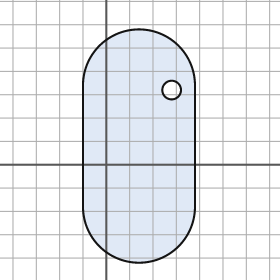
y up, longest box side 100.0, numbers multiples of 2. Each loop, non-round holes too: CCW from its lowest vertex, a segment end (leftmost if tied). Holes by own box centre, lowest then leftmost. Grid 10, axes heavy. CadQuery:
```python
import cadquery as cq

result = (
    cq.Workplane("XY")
    .moveTo(-10.0, -18.0)
    .threePointArc((14.0, -42.0), (38.0, -18.0))
    .lineTo(38.0, 34.0)
    .threePointArc((14.0, 58.0), (-10.0, 34.0))
    .close()
    .moveTo(28.0, 32.0)
    .circle(4.0)
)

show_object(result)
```